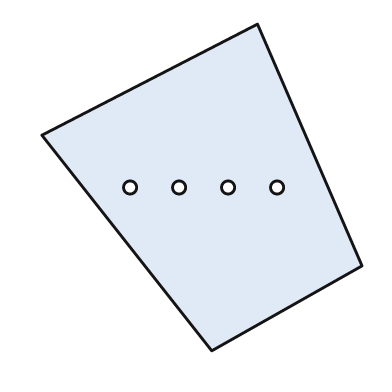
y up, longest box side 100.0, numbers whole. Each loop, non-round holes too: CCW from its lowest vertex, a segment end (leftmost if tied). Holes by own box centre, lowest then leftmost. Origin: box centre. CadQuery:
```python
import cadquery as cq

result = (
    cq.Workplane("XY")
    .moveTo(3.0, -50.0)
    .lineTo(49.0, -24.0)
    .lineTo(17.0, 50.0)
    .lineTo(-49.0, 16.0)
    .close()
    .moveTo(-22.0, 0.0)
    .circle(2.0)
    .moveTo(-7.0, 0.0)
    .circle(2.0)
    .moveTo(8.0, 0.0)
    .circle(2.0)
    .moveTo(23.0, 0.0)
    .circle(2.0)
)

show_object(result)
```